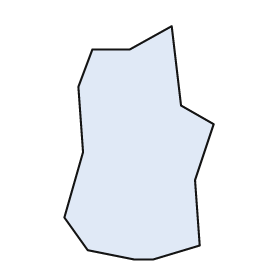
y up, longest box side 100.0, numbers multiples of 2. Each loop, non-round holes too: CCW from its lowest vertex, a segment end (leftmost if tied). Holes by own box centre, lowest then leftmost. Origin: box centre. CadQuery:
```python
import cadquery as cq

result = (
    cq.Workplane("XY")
    .moveTo(-2.0, -50.0)
    .lineTo(6.0, -50.0)
    .lineTo(26.0, -44.0)
    .lineTo(24.0, -16.0)
    .lineTo(32.0, 8.0)
    .lineTo(18.0, 16.0)
    .lineTo(14.0, 50.0)
    .lineTo(-4.0, 40.0)
    .lineTo(-20.0, 40.0)
    .lineTo(-26.0, 24.0)
    .lineTo(-24.0, -4.0)
    .lineTo(-32.0, -32.0)
    .lineTo(-22.0, -46.0)
    .close()
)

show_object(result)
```